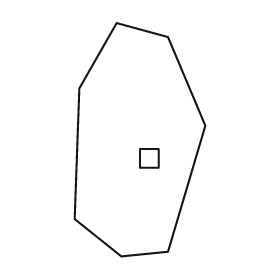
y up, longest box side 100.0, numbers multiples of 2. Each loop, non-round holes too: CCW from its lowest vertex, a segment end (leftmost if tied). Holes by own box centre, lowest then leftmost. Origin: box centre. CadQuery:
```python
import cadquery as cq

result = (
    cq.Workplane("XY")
    .moveTo(-8.0, -50.0)
    .lineTo(12.0, -48.0)
    .lineTo(28.0, 6.0)
    .lineTo(12.0, 44.0)
    .lineTo(-10.0, 50.0)
    .lineTo(-26.0, 22.0)
    .lineTo(-28.0, -34.0)
    .close()
    .moveTo(0.0, -12.0)
    .lineTo(8.0, -12.0)
    .lineTo(8.0, -4.0)
    .lineTo(0.0, -4.0)
    .close()
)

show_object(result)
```